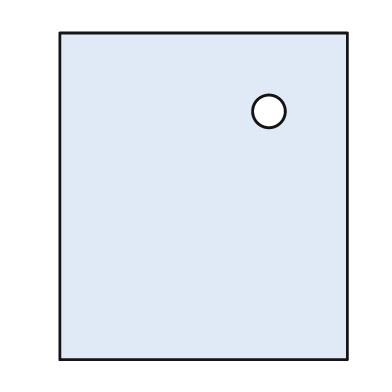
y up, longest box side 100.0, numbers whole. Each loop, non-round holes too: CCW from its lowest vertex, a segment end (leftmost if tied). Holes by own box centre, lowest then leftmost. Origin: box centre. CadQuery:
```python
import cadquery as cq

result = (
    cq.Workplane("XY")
    .moveTo(-44.0, -50.0)
    .lineTo(44.0, -50.0)
    .lineTo(44.0, 50.0)
    .lineTo(-44.0, 50.0)
    .close()
    .moveTo(20.0, 26.0)
    .circle(5.0)
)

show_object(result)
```